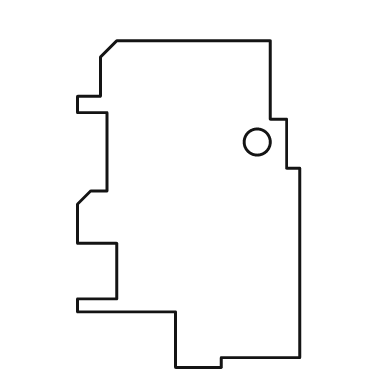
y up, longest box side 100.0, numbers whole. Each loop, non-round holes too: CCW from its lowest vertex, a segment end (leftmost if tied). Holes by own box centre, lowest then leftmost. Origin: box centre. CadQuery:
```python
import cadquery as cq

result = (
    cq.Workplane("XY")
    .moveTo(-4.0, -50.0)
    .lineTo(10.0, -50.0)
    .lineTo(10.0, -47.0)
    .lineTo(34.0, -47.0)
    .lineTo(34.0, 11.0)
    .lineTo(30.0, 11.0)
    .lineTo(30.0, 26.0)
    .lineTo(25.0, 26.0)
    .lineTo(25.0, 50.0)
    .lineTo(-22.0, 50.0)
    .lineTo(-27.0, 45.0)
    .lineTo(-27.0, 33.0)
    .lineTo(-34.0, 33.0)
    .lineTo(-34.0, 28.0)
    .lineTo(-25.0, 28.0)
    .lineTo(-25.0, 4.0)
    .lineTo(-30.0, 4.0)
    .lineTo(-34.0, 0.0)
    .lineTo(-34.0, -12.0)
    .lineTo(-22.0, -12.0)
    .lineTo(-22.0, -29.0)
    .lineTo(-34.0, -29.0)
    .lineTo(-34.0, -33.0)
    .lineTo(-4.0, -33.0)
    .close()
    .moveTo(21.0, 19.0)
    .circle(4.0)
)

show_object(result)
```